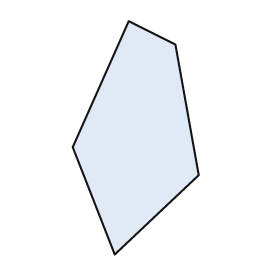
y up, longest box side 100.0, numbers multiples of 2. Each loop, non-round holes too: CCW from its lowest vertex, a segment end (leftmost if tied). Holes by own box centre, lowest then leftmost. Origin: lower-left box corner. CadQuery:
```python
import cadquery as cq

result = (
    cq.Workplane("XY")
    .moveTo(18.0, 0.0)
    .lineTo(54.0, 34.0)
    .lineTo(44.0, 90.0)
    .lineTo(24.0, 100.0)
    .lineTo(0.0, 46.0)
    .close()
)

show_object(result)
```